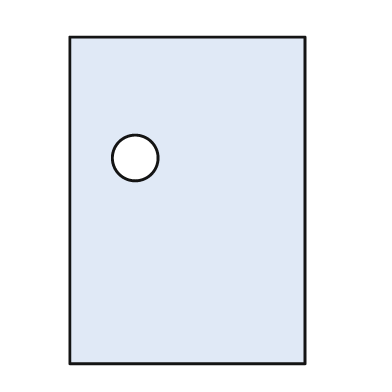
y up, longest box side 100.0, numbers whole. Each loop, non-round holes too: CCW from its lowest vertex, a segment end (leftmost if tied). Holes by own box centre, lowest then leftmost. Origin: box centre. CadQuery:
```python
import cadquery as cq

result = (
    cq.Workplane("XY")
    .moveTo(-36.0, -50.0)
    .lineTo(36.0, -50.0)
    .lineTo(36.0, 50.0)
    .lineTo(-36.0, 50.0)
    .close()
    .moveTo(-16.0, 13.0)
    .circle(7.0)
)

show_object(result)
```